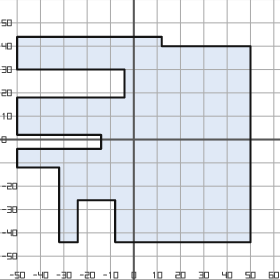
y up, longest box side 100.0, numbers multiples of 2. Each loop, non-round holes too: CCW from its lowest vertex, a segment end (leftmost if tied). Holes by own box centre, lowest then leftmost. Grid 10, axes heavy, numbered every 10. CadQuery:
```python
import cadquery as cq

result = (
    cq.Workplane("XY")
    .moveTo(-32.0, -44.0)
    .lineTo(-24.0, -44.0)
    .lineTo(-24.0, -26.0)
    .lineTo(-8.0, -26.0)
    .lineTo(-8.0, -44.0)
    .lineTo(50.0, -44.0)
    .lineTo(50.0, 40.0)
    .lineTo(12.0, 40.0)
    .lineTo(12.0, 44.0)
    .lineTo(-50.0, 44.0)
    .lineTo(-50.0, 30.0)
    .lineTo(-4.0, 30.0)
    .lineTo(-4.0, 18.0)
    .lineTo(-50.0, 18.0)
    .lineTo(-50.0, 2.0)
    .lineTo(-14.0, 2.0)
    .lineTo(-14.0, -4.0)
    .lineTo(-50.0, -4.0)
    .lineTo(-50.0, -12.0)
    .lineTo(-32.0, -12.0)
    .close()
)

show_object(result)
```